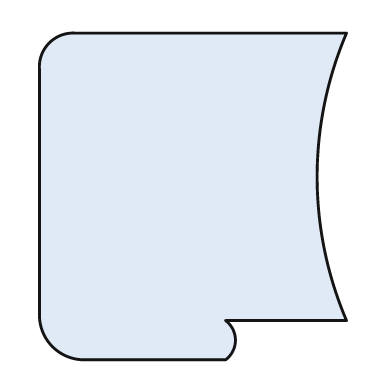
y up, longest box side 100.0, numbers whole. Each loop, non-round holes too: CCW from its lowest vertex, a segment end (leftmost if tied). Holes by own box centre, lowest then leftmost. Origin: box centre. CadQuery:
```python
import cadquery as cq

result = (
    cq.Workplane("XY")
    .moveTo(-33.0, -50.0)
    .lineTo(10.0, -50.0)
    .threePointArc((13.0, -44.0), (10.0, -38.0))
    .lineTo(47.0, -38.0)
    .threePointArc((38.0, 6.0), (47.0, 50.0))
    .lineTo(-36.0, 50.0)
    .threePointArc((-44.0, 47.0), (-47.0, 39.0))
    .lineTo(-47.0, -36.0)
    .threePointArc((-43.0, -46.0), (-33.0, -50.0))
    .close()
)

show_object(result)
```